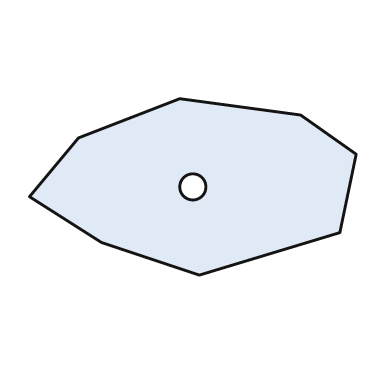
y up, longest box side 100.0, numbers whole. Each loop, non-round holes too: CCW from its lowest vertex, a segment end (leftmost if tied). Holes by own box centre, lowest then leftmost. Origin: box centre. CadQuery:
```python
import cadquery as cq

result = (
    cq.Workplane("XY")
    .moveTo(2.0, -27.0)
    .lineTo(45.0, -14.0)
    .lineTo(50.0, 10.0)
    .lineTo(33.0, 22.0)
    .lineTo(-4.0, 27.0)
    .lineTo(-35.0, 15.0)
    .lineTo(-50.0, -3.0)
    .lineTo(-28.0, -17.0)
    .close()
    .moveTo(0.0, 0.0)
    .circle(4.0)
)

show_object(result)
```